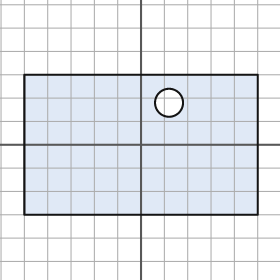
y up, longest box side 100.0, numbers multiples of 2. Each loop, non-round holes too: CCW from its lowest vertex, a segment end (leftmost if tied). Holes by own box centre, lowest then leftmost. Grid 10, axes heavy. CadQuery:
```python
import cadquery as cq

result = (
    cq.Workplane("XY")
    .moveTo(-50.0, -30.0)
    .lineTo(50.0, -30.0)
    .lineTo(50.0, 30.0)
    .lineTo(-50.0, 30.0)
    .close()
    .moveTo(12.0, 18.0)
    .circle(6.0)
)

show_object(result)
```